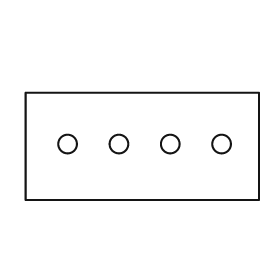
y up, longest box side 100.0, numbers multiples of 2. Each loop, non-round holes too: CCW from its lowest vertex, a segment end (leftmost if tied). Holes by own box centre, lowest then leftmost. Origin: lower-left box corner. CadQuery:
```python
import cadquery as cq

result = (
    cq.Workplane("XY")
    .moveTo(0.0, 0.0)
    .lineTo(100.0, 0.0)
    .lineTo(100.0, 46.0)
    .lineTo(0.0, 46.0)
    .close()
    .moveTo(18.0, 24.0)
    .circle(4.0)
    .moveTo(40.0, 24.0)
    .circle(4.0)
    .moveTo(62.0, 24.0)
    .circle(4.0)
    .moveTo(84.0, 24.0)
    .circle(4.0)
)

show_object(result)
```